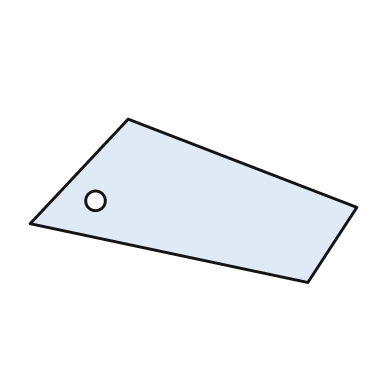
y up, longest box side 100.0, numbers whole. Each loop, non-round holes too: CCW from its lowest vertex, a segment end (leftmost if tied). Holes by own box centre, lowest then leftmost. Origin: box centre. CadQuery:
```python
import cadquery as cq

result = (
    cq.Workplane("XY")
    .moveTo(35.0, -25.0)
    .lineTo(50.0, -2.0)
    .lineTo(-20.0, 25.0)
    .lineTo(-50.0, -7.0)
    .close()
    .moveTo(-30.0, 0.0)
    .circle(3.0)
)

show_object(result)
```